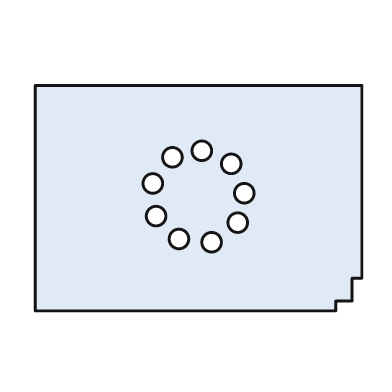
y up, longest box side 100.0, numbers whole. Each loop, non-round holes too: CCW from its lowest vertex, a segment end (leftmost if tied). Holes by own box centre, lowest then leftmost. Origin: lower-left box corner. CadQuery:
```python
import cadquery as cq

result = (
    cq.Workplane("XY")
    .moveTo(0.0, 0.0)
    .lineTo(92.0, 0.0)
    .lineTo(92.0, 3.0)
    .lineTo(97.0, 3.0)
    .lineTo(97.0, 10.0)
    .lineTo(100.0, 10.0)
    .lineTo(100.0, 69.0)
    .lineTo(0.0, 69.0)
    .close()
    .moveTo(54.0, 21.0)
    .circle(3.0)
    .moveTo(44.0, 22.0)
    .circle(3.0)
    .moveTo(62.0, 27.0)
    .circle(3.0)
    .moveTo(37.0, 29.0)
    .circle(3.0)
    .moveTo(64.0, 36.0)
    .circle(3.0)
    .moveTo(36.0, 39.0)
    .circle(3.0)
    .moveTo(60.0, 45.0)
    .circle(3.0)
    .moveTo(42.0, 47.0)
    .circle(3.0)
    .moveTo(51.0, 49.0)
    .circle(3.0)
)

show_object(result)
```